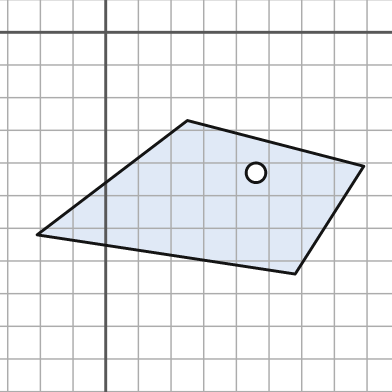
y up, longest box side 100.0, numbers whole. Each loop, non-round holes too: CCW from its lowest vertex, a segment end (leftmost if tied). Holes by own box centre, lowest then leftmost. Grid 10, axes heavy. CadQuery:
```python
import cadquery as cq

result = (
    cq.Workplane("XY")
    .moveTo(58.0, -74.0)
    .lineTo(79.0, -41.0)
    .lineTo(25.0, -27.0)
    .lineTo(-21.0, -62.0)
    .close()
    .moveTo(46.0, -43.0)
    .circle(3.0)
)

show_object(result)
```